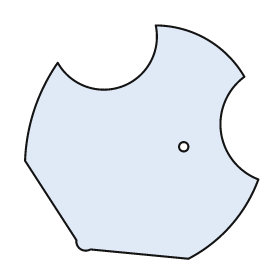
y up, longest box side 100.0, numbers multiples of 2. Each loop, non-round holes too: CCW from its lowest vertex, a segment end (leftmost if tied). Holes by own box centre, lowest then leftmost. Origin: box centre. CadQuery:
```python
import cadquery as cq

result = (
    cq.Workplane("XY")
    .moveTo(20.0, -50.0)
    .threePointArc((38.0, -36.0), (50.0, -16.0))
    .threePointArc((34.0, 4.0), (44.0, 28.0))
    .threePointArc((28.0, 44.0), (6.0, 50.0))
    .threePointArc((-8.0, 24.0), (-36.0, 34.0))
    .threePointArc((-46.0, 14.0), (-50.0, -8.0))
    .lineTo(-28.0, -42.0)
    .threePointArc((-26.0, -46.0), (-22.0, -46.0))
    .close()
    .moveTo(18.0, -2.0)
    .circle(2.0)
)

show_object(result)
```